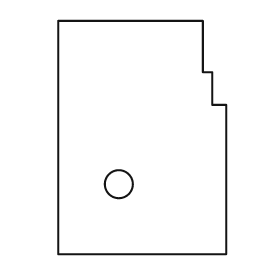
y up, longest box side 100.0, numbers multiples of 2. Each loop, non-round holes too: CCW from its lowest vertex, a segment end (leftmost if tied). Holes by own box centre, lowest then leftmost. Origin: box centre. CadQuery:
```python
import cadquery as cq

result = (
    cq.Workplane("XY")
    .moveTo(-36.0, -50.0)
    .lineTo(36.0, -50.0)
    .lineTo(36.0, 14.0)
    .lineTo(30.0, 14.0)
    .lineTo(30.0, 28.0)
    .lineTo(26.0, 28.0)
    .lineTo(26.0, 50.0)
    .lineTo(-36.0, 50.0)
    .close()
    .moveTo(-10.0, -20.0)
    .circle(6.0)
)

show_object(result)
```